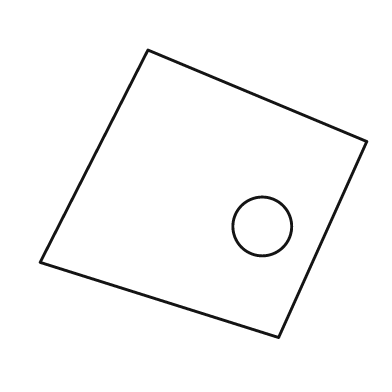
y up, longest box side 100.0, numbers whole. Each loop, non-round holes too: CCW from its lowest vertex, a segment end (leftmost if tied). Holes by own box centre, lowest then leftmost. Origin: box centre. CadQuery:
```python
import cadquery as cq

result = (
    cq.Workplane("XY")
    .moveTo(23.0, -44.0)
    .lineTo(50.0, 16.0)
    .lineTo(-17.0, 44.0)
    .lineTo(-50.0, -21.0)
    .close()
    .moveTo(18.0, -10.0)
    .circle(9.0)
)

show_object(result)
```